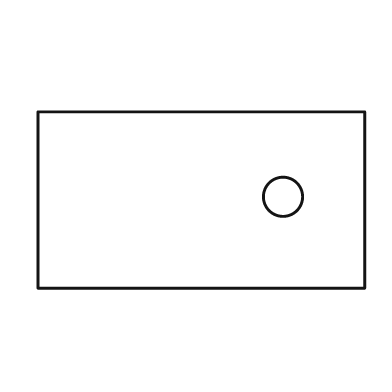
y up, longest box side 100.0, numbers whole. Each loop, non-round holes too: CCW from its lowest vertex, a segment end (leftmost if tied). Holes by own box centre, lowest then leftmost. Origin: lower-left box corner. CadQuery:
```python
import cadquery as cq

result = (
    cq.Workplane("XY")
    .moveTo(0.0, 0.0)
    .lineTo(100.0, 0.0)
    .lineTo(100.0, 54.0)
    .lineTo(0.0, 54.0)
    .close()
    .moveTo(75.0, 28.0)
    .circle(6.0)
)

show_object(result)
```